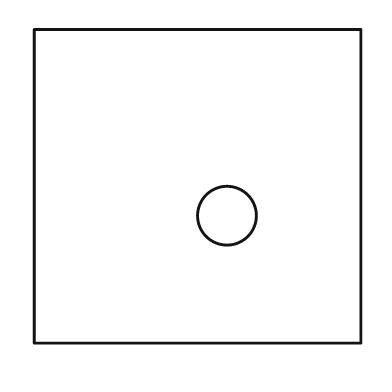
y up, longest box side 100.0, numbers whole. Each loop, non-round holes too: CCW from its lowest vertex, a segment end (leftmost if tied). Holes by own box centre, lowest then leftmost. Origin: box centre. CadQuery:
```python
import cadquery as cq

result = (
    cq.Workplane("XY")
    .moveTo(-50.0, -48.0)
    .lineTo(50.0, -48.0)
    .lineTo(50.0, 48.0)
    .lineTo(-50.0, 48.0)
    .close()
    .moveTo(9.0, -9.0)
    .circle(9.0)
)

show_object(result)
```